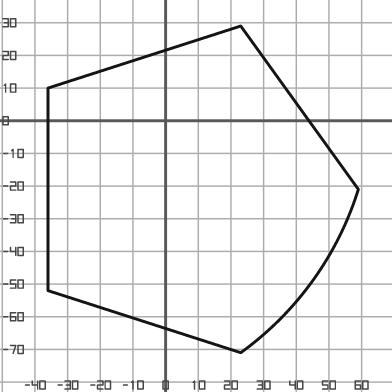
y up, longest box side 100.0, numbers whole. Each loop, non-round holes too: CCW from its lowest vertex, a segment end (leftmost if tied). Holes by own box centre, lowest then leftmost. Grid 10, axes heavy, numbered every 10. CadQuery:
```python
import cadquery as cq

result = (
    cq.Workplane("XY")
    .moveTo(23.0, -71.0)
    .threePointArc((45.0, -49.0), (59.0, -21.0))
    .lineTo(23.0, 29.0)
    .lineTo(-36.0, 10.0)
    .lineTo(-36.0, -52.0)
    .close()
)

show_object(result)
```